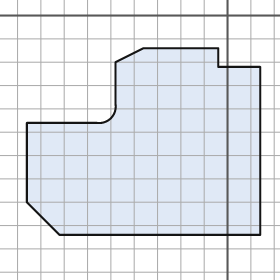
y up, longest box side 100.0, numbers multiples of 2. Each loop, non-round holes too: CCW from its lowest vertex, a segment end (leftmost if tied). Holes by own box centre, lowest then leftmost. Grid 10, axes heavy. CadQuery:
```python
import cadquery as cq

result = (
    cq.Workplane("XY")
    .moveTo(-72.0, -94.0)
    .lineTo(14.0, -94.0)
    .lineTo(14.0, -22.0)
    .lineTo(-4.0, -22.0)
    .lineTo(-4.0, -14.0)
    .lineTo(-36.0, -14.0)
    .lineTo(-48.0, -20.0)
    .lineTo(-48.0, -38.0)
    .threePointArc((-50.0, -44.0), (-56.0, -46.0))
    .lineTo(-86.0, -46.0)
    .lineTo(-86.0, -80.0)
    .close()
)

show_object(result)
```